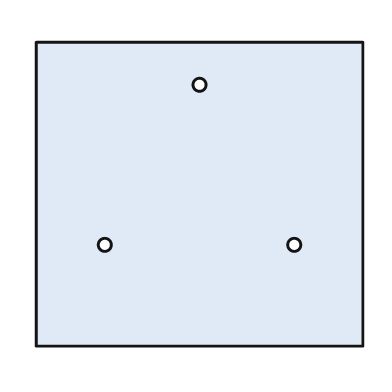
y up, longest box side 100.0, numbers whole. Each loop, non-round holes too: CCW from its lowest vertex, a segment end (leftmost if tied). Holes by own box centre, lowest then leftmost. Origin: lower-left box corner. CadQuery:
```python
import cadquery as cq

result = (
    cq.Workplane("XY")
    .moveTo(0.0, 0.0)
    .lineTo(100.0, 0.0)
    .lineTo(100.0, 93.0)
    .lineTo(0.0, 93.0)
    .close()
    .moveTo(21.0, 31.0)
    .circle(2.0)
    .moveTo(79.0, 31.0)
    .circle(2.0)
    .moveTo(50.0, 80.0)
    .circle(2.0)
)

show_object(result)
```